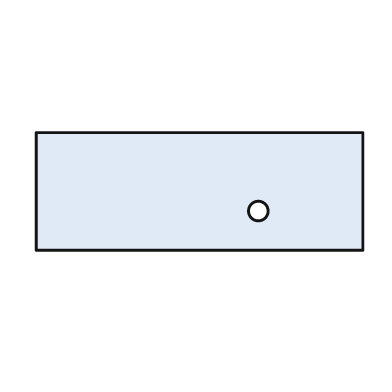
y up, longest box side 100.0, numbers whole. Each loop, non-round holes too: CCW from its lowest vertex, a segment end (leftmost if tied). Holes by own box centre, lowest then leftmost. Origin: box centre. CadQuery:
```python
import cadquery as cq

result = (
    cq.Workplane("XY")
    .moveTo(-50.0, -18.0)
    .lineTo(50.0, -18.0)
    .lineTo(50.0, 18.0)
    .lineTo(-50.0, 18.0)
    .close()
    .moveTo(18.0, -6.0)
    .circle(3.0)
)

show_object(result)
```